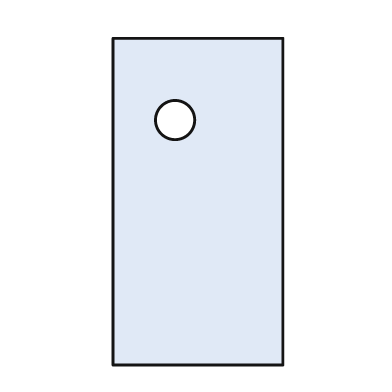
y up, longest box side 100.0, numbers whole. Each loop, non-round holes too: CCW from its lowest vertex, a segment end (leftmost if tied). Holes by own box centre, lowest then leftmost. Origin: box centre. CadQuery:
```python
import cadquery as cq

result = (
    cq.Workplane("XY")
    .moveTo(-26.0, -50.0)
    .lineTo(26.0, -50.0)
    .lineTo(26.0, 50.0)
    .lineTo(-26.0, 50.0)
    .close()
    .moveTo(-7.0, 25.0)
    .circle(6.0)
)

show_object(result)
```